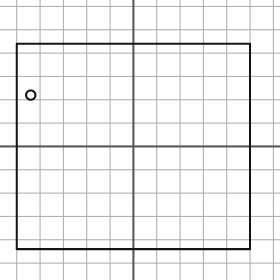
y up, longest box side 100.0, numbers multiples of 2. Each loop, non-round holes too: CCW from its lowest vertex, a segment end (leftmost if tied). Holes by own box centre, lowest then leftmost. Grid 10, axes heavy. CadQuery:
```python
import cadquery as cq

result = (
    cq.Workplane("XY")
    .moveTo(-50.0, -44.0)
    .lineTo(50.0, -44.0)
    .lineTo(50.0, 44.0)
    .lineTo(-50.0, 44.0)
    .close()
    .moveTo(-44.0, 22.0)
    .circle(2.0)
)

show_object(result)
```